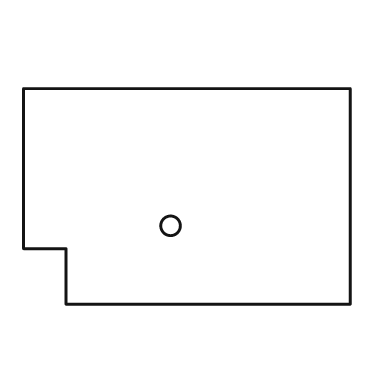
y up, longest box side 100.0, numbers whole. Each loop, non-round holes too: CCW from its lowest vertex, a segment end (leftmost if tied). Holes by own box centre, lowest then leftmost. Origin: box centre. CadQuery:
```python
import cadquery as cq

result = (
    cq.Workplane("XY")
    .moveTo(-37.0, -33.0)
    .lineTo(50.0, -33.0)
    .lineTo(50.0, 33.0)
    .lineTo(-50.0, 33.0)
    .lineTo(-50.0, -16.0)
    .lineTo(-37.0, -16.0)
    .close()
    .moveTo(-5.0, -9.0)
    .circle(3.0)
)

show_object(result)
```